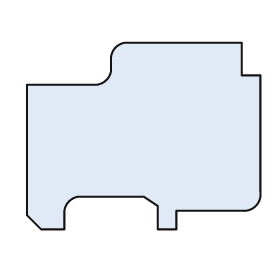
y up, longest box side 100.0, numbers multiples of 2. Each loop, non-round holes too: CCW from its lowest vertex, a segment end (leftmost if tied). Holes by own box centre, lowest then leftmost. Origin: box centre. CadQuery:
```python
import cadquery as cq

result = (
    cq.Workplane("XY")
    .moveTo(-44.0, -40.0)
    .lineTo(-34.0, -40.0)
    .lineTo(-34.0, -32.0)
    .threePointArc((-32.0, -28.0), (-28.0, -26.0))
    .lineTo(0.0, -26.0)
    .lineTo(6.0, -30.0)
    .lineTo(6.0, -40.0)
    .lineTo(14.0, -40.0)
    .lineTo(14.0, -32.0)
    .lineTo(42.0, -32.0)
    .threePointArc((48.0, -30.0), (50.0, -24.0))
    .lineTo(50.0, 26.0)
    .lineTo(42.0, 26.0)
    .lineTo(42.0, 40.0)
    .lineTo(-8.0, 40.0)
    .threePointArc((-12.0, 38.0), (-14.0, 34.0))
    .lineTo(-14.0, 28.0)
    .threePointArc((-16.0, 24.0), (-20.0, 22.0))
    .lineTo(-50.0, 22.0)
    .lineTo(-50.0, -34.0)
    .close()
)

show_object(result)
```